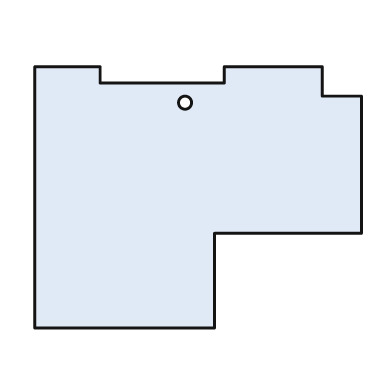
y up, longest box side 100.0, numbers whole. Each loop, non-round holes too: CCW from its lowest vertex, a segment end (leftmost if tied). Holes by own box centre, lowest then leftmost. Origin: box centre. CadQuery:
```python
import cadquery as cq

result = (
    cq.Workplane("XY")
    .moveTo(-50.0, -40.0)
    .lineTo(5.0, -40.0)
    .lineTo(5.0, -11.0)
    .lineTo(50.0, -11.0)
    .lineTo(50.0, 31.0)
    .lineTo(38.0, 31.0)
    .lineTo(38.0, 40.0)
    .lineTo(8.0, 40.0)
    .lineTo(8.0, 35.0)
    .lineTo(-30.0, 35.0)
    .lineTo(-30.0, 40.0)
    .lineTo(-50.0, 40.0)
    .close()
    .moveTo(-4.0, 29.0)
    .circle(2.0)
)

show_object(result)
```